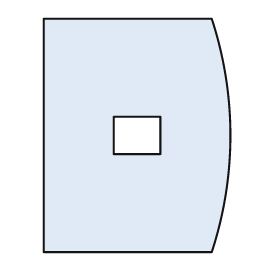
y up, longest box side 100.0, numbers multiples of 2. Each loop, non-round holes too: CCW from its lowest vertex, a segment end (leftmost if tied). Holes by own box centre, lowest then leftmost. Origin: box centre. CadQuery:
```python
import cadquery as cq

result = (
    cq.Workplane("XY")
    .moveTo(-40.0, -50.0)
    .lineTo(32.0, -50.0)
    .threePointArc((40.0, 0.0), (32.0, 50.0))
    .lineTo(-40.0, 50.0)
    .close()
    .moveTo(-10.0, -8.0)
    .lineTo(10.0, -8.0)
    .lineTo(10.0, 8.0)
    .lineTo(-10.0, 8.0)
    .close()
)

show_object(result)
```